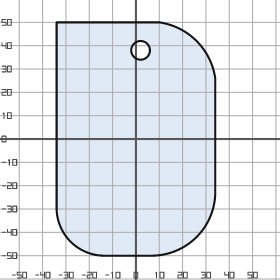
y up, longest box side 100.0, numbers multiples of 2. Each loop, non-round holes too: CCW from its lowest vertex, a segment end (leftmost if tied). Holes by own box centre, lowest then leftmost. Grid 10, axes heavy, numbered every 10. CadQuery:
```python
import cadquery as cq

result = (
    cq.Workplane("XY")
    .moveTo(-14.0, -50.0)
    .lineTo(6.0, -50.0)
    .threePointArc((26.0, -42.0), (34.0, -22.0))
    .lineTo(34.0, 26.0)
    .threePointArc((26.0, 42.0), (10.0, 50.0))
    .lineTo(-34.0, 50.0)
    .lineTo(-34.0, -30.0)
    .threePointArc((-28.0, -44.0), (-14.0, -50.0))
    .close()
    .moveTo(2.0, 38.0)
    .circle(4.0)
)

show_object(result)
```